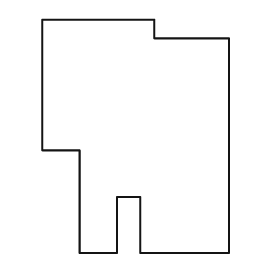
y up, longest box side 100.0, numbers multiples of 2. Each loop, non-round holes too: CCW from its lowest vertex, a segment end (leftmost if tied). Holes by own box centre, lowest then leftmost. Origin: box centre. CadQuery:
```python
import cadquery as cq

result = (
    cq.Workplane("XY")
    .moveTo(-24.0, -50.0)
    .lineTo(-8.0, -50.0)
    .lineTo(-8.0, -26.0)
    .lineTo(2.0, -26.0)
    .lineTo(2.0, -50.0)
    .lineTo(40.0, -50.0)
    .lineTo(40.0, 42.0)
    .lineTo(8.0, 42.0)
    .lineTo(8.0, 50.0)
    .lineTo(-40.0, 50.0)
    .lineTo(-40.0, -6.0)
    .lineTo(-24.0, -6.0)
    .close()
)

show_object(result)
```